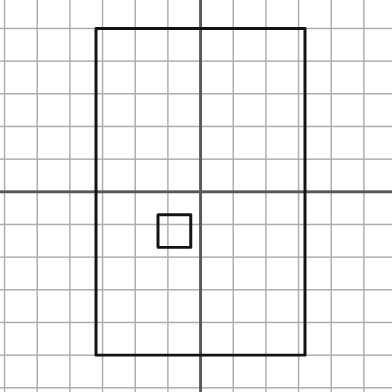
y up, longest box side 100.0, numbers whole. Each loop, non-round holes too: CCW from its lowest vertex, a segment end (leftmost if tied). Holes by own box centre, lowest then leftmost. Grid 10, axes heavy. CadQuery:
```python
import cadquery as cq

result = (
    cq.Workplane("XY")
    .moveTo(-32.0, -50.0)
    .lineTo(32.0, -50.0)
    .lineTo(32.0, 50.0)
    .lineTo(-32.0, 50.0)
    .close()
    .moveTo(-13.0, -17.0)
    .lineTo(-3.0, -17.0)
    .lineTo(-3.0, -7.0)
    .lineTo(-13.0, -7.0)
    .close()
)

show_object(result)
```